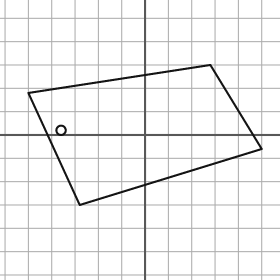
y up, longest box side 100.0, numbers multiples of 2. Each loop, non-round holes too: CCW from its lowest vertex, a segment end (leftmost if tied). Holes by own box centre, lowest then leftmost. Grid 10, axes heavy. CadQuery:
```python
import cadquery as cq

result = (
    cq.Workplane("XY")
    .moveTo(-28.0, -30.0)
    .lineTo(50.0, -6.0)
    .lineTo(28.0, 30.0)
    .lineTo(-50.0, 18.0)
    .close()
    .moveTo(-36.0, 2.0)
    .circle(2.0)
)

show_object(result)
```